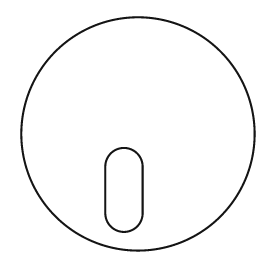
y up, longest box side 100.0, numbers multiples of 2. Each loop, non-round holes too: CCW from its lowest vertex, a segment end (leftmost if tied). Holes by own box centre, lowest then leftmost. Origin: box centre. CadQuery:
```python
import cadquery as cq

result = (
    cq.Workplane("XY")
    .moveTo(0.0, 0.0)
    .circle(50.0)
    .moveTo(-14.0, -34.0)
    .threePointArc((-6.0, -42.0), (2.0, -34.0))
    .lineTo(2.0, -14.0)
    .threePointArc((-6.0, -6.0), (-14.0, -14.0))
    .close()
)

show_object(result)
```